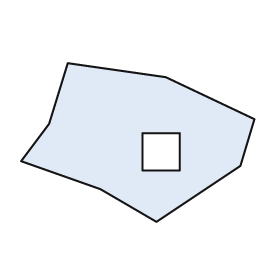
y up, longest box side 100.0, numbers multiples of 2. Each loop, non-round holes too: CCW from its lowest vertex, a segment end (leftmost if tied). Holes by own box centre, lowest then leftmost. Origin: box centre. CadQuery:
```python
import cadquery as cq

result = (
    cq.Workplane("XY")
    .moveTo(8.0, -34.0)
    .lineTo(44.0, -10.0)
    .lineTo(50.0, 10.0)
    .lineTo(12.0, 28.0)
    .lineTo(-30.0, 34.0)
    .lineTo(-38.0, 8.0)
    .lineTo(-50.0, -8.0)
    .lineTo(-16.0, -20.0)
    .close()
    .moveTo(2.0, -12.0)
    .lineTo(18.0, -12.0)
    .lineTo(18.0, 4.0)
    .lineTo(2.0, 4.0)
    .close()
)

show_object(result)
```